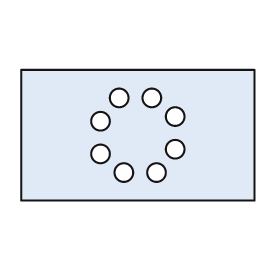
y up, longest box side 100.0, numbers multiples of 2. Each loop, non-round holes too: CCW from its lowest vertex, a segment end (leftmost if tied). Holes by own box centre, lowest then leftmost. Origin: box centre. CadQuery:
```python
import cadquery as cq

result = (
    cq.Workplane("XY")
    .moveTo(-50.0, -28.0)
    .lineTo(50.0, -28.0)
    .lineTo(50.0, 28.0)
    .lineTo(-50.0, 28.0)
    .close()
    .moveTo(-6.0, -16.0)
    .circle(4.0)
    .moveTo(8.0, -16.0)
    .circle(4.0)
    .moveTo(-16.0, -8.0)
    .circle(4.0)
    .moveTo(16.0, -6.0)
    .circle(4.0)
    .moveTo(-16.0, 6.0)
    .circle(4.0)
    .moveTo(16.0, 8.0)
    .circle(4.0)
    .moveTo(-8.0, 16.0)
    .circle(4.0)
    .moveTo(6.0, 16.0)
    .circle(4.0)
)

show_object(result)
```